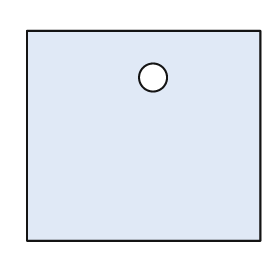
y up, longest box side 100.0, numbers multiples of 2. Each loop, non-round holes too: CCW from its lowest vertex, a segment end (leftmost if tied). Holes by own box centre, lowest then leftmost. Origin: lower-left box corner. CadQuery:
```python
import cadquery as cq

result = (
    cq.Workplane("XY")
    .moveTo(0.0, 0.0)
    .lineTo(100.0, 0.0)
    .lineTo(100.0, 90.0)
    .lineTo(0.0, 90.0)
    .close()
    .moveTo(54.0, 70.0)
    .circle(6.0)
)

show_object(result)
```